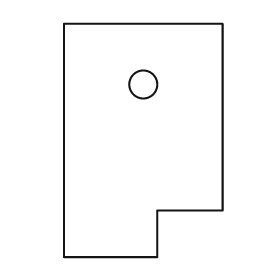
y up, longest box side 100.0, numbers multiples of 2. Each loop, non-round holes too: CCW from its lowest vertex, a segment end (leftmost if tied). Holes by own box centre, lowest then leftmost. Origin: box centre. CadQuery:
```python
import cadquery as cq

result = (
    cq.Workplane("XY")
    .moveTo(-34.0, -50.0)
    .lineTo(6.0, -50.0)
    .lineTo(6.0, -30.0)
    .lineTo(34.0, -30.0)
    .lineTo(34.0, 50.0)
    .lineTo(-34.0, 50.0)
    .close()
    .moveTo(0.0, 24.0)
    .circle(6.0)
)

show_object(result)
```